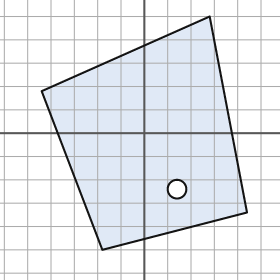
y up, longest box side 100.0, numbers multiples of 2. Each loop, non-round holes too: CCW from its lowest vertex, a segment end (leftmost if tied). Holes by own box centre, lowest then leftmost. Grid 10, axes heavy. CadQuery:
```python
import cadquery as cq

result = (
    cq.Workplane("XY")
    .moveTo(-18.0, -50.0)
    .lineTo(44.0, -34.0)
    .lineTo(28.0, 50.0)
    .lineTo(-44.0, 18.0)
    .close()
    .moveTo(14.0, -24.0)
    .circle(4.0)
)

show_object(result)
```